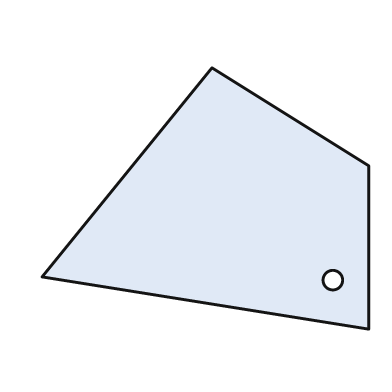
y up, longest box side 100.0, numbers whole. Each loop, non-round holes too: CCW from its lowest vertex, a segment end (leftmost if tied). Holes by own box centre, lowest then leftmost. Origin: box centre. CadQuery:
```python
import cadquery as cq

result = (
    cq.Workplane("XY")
    .moveTo(50.0, -40.0)
    .lineTo(50.0, 10.0)
    .lineTo(2.0, 40.0)
    .lineTo(-50.0, -24.0)
    .close()
    .moveTo(39.0, -25.0)
    .circle(3.0)
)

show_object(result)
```